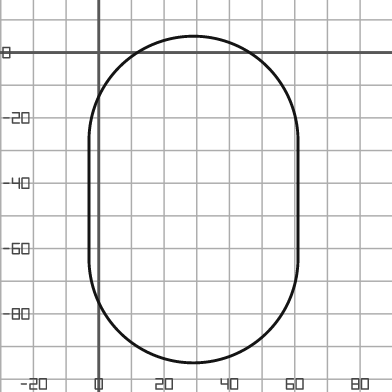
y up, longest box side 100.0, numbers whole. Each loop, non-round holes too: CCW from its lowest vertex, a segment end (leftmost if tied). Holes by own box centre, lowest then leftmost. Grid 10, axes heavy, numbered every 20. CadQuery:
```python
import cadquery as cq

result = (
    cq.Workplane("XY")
    .moveTo(-3.0, -63.0)
    .threePointArc((29.0, -95.0), (61.0, -63.0))
    .lineTo(61.0, -27.0)
    .threePointArc((29.0, 5.0), (-3.0, -27.0))
    .close()
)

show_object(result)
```